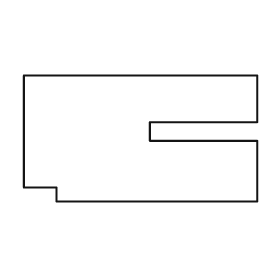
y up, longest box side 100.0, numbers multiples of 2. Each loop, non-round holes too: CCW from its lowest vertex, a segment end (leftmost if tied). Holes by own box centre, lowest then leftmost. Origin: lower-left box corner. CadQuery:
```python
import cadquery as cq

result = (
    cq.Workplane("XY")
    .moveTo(14.0, 0.0)
    .lineTo(100.0, 0.0)
    .lineTo(100.0, 26.0)
    .lineTo(54.0, 26.0)
    .lineTo(54.0, 34.0)
    .lineTo(100.0, 34.0)
    .lineTo(100.0, 54.0)
    .lineTo(0.0, 54.0)
    .lineTo(0.0, 6.0)
    .lineTo(14.0, 6.0)
    .close()
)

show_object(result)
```